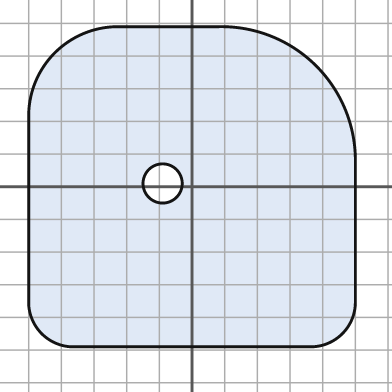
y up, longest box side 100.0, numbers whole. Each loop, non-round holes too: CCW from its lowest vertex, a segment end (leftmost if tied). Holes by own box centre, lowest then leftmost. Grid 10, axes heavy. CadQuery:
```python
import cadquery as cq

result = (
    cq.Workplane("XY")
    .moveTo(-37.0, -49.0)
    .lineTo(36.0, -49.0)
    .threePointArc((46.0, -45.0), (50.0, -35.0))
    .lineTo(50.0, 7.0)
    .threePointArc((38.0, 37.0), (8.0, 49.0))
    .lineTo(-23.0, 49.0)
    .threePointArc((-42.0, 41.0), (-50.0, 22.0))
    .lineTo(-50.0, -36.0)
    .threePointArc((-46.0, -45.0), (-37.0, -49.0))
    .close()
    .moveTo(-9.0, 1.0)
    .circle(6.0)
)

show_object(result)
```